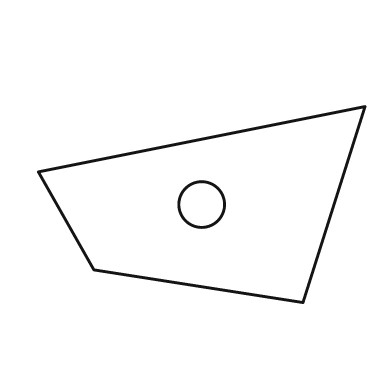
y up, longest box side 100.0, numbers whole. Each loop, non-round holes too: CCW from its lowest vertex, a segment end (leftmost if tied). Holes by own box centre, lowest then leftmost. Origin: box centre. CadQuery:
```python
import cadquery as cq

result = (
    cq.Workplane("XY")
    .moveTo(31.0, -30.0)
    .lineTo(50.0, 30.0)
    .lineTo(-50.0, 10.0)
    .lineTo(-33.0, -20.0)
    .close()
    .moveTo(0.0, 0.0)
    .circle(7.0)
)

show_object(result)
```